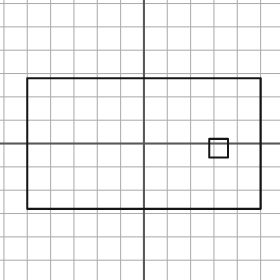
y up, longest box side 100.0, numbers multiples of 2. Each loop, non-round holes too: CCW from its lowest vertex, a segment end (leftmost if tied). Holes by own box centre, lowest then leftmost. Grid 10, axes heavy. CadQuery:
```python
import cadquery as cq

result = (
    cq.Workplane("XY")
    .moveTo(-50.0, -28.0)
    .lineTo(50.0, -28.0)
    .lineTo(50.0, 28.0)
    .lineTo(-50.0, 28.0)
    .close()
    .moveTo(28.0, -6.0)
    .lineTo(36.0, -6.0)
    .lineTo(36.0, 2.0)
    .lineTo(28.0, 2.0)
    .close()
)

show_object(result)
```